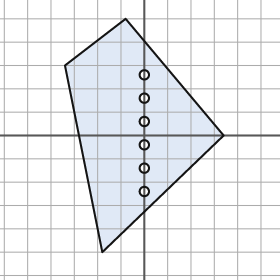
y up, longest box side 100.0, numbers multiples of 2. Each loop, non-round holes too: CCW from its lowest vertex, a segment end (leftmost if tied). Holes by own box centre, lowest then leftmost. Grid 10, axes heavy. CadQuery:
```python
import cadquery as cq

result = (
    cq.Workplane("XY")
    .moveTo(-18.0, -50.0)
    .lineTo(34.0, 0.0)
    .lineTo(-8.0, 50.0)
    .lineTo(-34.0, 30.0)
    .close()
    .moveTo(0.0, -24.0)
    .circle(2.0)
    .moveTo(0.0, -14.0)
    .circle(2.0)
    .moveTo(0.0, -4.0)
    .circle(2.0)
    .moveTo(0.0, 6.0)
    .circle(2.0)
    .moveTo(0.0, 16.0)
    .circle(2.0)
    .moveTo(0.0, 26.0)
    .circle(2.0)
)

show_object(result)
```